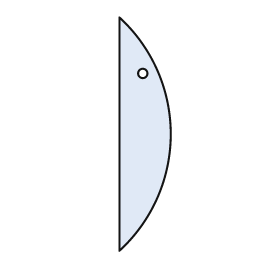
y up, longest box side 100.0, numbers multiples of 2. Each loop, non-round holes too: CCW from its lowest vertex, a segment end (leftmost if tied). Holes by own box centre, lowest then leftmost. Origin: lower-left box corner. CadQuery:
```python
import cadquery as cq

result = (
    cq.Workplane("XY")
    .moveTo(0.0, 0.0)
    .threePointArc((22.0, 50.0), (0.0, 100.0))
    .close()
    .moveTo(10.0, 76.0)
    .circle(2.0)
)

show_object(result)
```